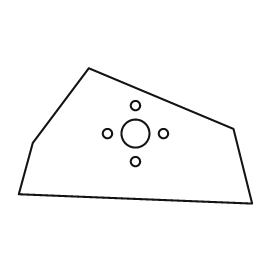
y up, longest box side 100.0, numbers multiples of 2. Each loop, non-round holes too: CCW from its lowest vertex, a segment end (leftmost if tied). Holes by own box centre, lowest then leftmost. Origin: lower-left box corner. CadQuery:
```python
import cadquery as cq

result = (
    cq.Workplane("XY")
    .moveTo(100.0, 0.0)
    .lineTo(92.0, 32.0)
    .lineTo(30.0, 58.0)
    .lineTo(6.0, 26.0)
    .lineTo(0.0, 4.0)
    .close()
    .moveTo(50.0, 18.0)
    .circle(2.0)
    .moveTo(38.0, 30.0)
    .circle(2.0)
    .moveTo(50.0, 30.0)
    .circle(6.0)
    .moveTo(62.0, 30.0)
    .circle(2.0)
    .moveTo(50.0, 42.0)
    .circle(2.0)
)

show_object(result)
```